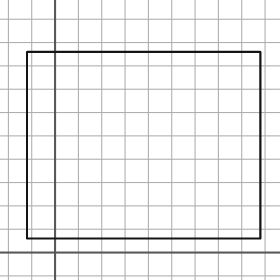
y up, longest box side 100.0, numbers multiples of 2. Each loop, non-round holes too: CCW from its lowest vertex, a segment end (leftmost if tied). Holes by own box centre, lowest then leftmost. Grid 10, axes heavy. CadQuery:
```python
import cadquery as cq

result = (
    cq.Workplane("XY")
    .moveTo(-12.0, 6.0)
    .lineTo(88.0, 6.0)
    .lineTo(88.0, 86.0)
    .lineTo(-12.0, 86.0)
    .close()
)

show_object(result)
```